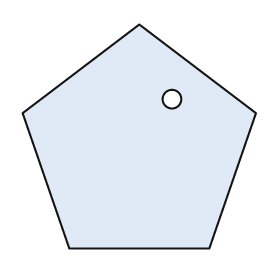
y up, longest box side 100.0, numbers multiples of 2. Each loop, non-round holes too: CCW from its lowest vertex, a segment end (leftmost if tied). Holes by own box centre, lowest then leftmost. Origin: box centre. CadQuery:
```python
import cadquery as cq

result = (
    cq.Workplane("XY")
    .moveTo(-30.0, -48.0)
    .lineTo(30.0, -48.0)
    .lineTo(50.0, 10.0)
    .lineTo(0.0, 48.0)
    .lineTo(-50.0, 10.0)
    .close()
    .moveTo(14.0, 16.0)
    .circle(4.0)
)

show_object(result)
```